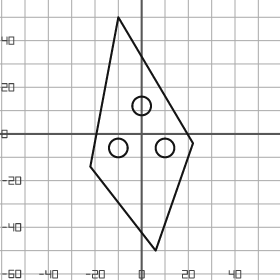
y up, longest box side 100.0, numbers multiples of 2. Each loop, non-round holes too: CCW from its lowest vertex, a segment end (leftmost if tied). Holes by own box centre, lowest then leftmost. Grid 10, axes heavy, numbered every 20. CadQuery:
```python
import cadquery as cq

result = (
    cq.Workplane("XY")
    .moveTo(6.0, -50.0)
    .lineTo(22.0, -4.0)
    .lineTo(-10.0, 50.0)
    .lineTo(-22.0, -14.0)
    .close()
    .moveTo(-10.0, -6.0)
    .circle(4.0)
    .moveTo(10.0, -6.0)
    .circle(4.0)
    .moveTo(0.0, 12.0)
    .circle(4.0)
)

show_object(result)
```